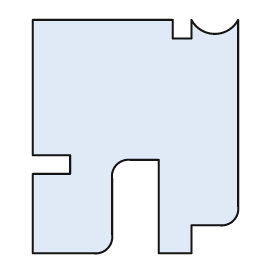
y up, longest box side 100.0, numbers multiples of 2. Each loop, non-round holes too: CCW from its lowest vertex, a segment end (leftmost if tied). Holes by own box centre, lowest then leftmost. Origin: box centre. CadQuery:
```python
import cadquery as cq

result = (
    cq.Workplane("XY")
    .moveTo(-44.0, -50.0)
    .lineTo(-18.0, -50.0)
    .threePointArc((-12.0, -48.0), (-10.0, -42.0))
    .lineTo(-10.0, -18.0)
    .threePointArc((-8.0, -12.0), (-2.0, -10.0))
    .lineTo(10.0, -10.0)
    .lineTo(10.0, -50.0)
    .lineTo(24.0, -50.0)
    .lineTo(24.0, -38.0)
    .lineTo(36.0, -38.0)
    .threePointArc((42.0, -36.0), (44.0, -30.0))
    .lineTo(44.0, 50.0)
    .threePointArc((34.0, 44.0), (24.0, 50.0))
    .lineTo(24.0, 42.0)
    .lineTo(16.0, 42.0)
    .lineTo(16.0, 50.0)
    .lineTo(-44.0, 50.0)
    .lineTo(-44.0, -8.0)
    .lineTo(-28.0, -8.0)
    .lineTo(-28.0, -16.0)
    .lineTo(-44.0, -16.0)
    .close()
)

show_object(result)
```